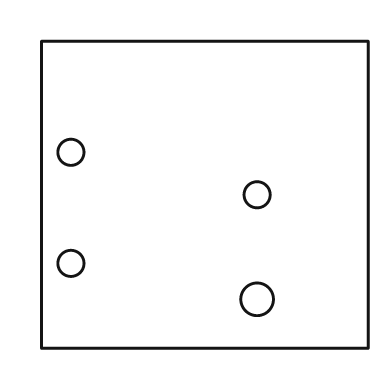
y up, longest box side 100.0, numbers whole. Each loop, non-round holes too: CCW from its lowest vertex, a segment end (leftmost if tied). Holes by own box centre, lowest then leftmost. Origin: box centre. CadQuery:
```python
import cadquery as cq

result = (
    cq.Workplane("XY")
    .moveTo(-50.0, -47.0)
    .lineTo(50.0, -47.0)
    .lineTo(50.0, 47.0)
    .lineTo(-50.0, 47.0)
    .close()
    .moveTo(16.0, -32.0)
    .circle(5.0)
    .moveTo(-41.0, -21.0)
    .circle(4.0)
    .moveTo(16.0, 0.0)
    .circle(4.0)
    .moveTo(-41.0, 13.0)
    .circle(4.0)
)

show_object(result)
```